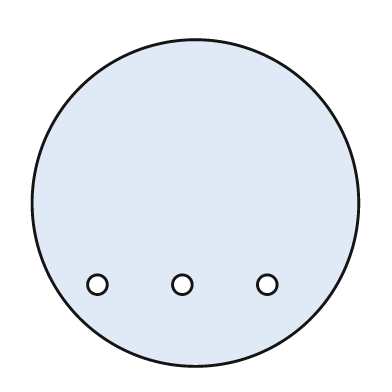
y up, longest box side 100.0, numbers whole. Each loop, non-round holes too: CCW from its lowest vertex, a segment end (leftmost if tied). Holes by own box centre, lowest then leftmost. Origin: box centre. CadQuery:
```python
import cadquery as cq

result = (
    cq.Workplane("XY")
    .moveTo(0.0, 0.0)
    .circle(50.0)
    .moveTo(-30.0, -25.0)
    .circle(3.0)
    .moveTo(-4.0, -25.0)
    .circle(3.0)
    .moveTo(22.0, -25.0)
    .circle(3.0)
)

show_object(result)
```